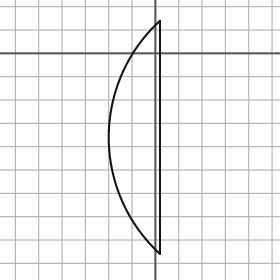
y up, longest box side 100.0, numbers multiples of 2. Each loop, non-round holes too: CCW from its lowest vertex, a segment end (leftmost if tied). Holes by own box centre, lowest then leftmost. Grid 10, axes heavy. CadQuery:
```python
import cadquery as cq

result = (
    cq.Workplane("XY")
    .moveTo(2.0, -86.0)
    .lineTo(2.0, 14.0)
    .threePointArc((-20.0, -36.0), (2.0, -86.0))
    .close()
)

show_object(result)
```